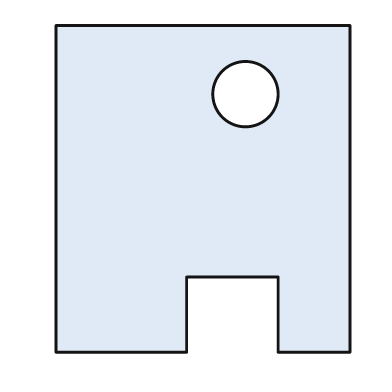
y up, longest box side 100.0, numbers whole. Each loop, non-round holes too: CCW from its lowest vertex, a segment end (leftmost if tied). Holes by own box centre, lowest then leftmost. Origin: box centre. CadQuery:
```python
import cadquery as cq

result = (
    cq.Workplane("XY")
    .moveTo(-45.0, -50.0)
    .lineTo(-5.0, -50.0)
    .lineTo(-5.0, -27.0)
    .lineTo(23.0, -27.0)
    .lineTo(23.0, -50.0)
    .lineTo(45.0, -50.0)
    .lineTo(45.0, 50.0)
    .lineTo(-45.0, 50.0)
    .close()
    .moveTo(13.0, 29.0)
    .circle(10.0)
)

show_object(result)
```